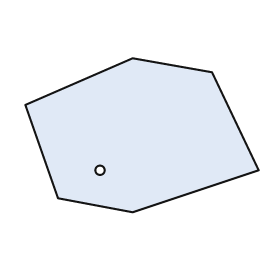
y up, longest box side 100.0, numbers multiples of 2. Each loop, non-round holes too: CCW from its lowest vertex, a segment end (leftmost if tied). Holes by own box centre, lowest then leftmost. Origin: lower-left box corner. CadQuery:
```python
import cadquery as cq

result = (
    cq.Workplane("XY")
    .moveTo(46.0, 0.0)
    .lineTo(100.0, 18.0)
    .lineTo(80.0, 60.0)
    .lineTo(46.0, 66.0)
    .lineTo(0.0, 46.0)
    .lineTo(14.0, 6.0)
    .close()
    .moveTo(32.0, 18.0)
    .circle(2.0)
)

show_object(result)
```